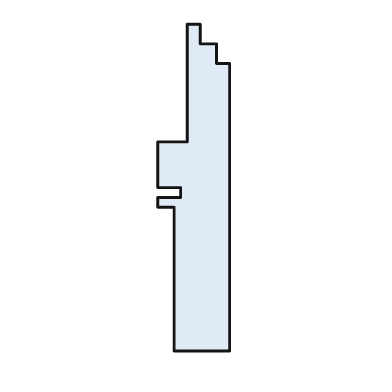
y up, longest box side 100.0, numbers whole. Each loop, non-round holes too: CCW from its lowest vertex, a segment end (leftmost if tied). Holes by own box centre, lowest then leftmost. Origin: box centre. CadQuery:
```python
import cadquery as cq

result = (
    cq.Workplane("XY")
    .moveTo(-6.0, -50.0)
    .lineTo(11.0, -50.0)
    .lineTo(11.0, 38.0)
    .lineTo(7.0, 38.0)
    .lineTo(7.0, 44.0)
    .lineTo(2.0, 44.0)
    .lineTo(2.0, 50.0)
    .lineTo(-2.0, 50.0)
    .lineTo(-2.0, 14.0)
    .lineTo(-11.0, 14.0)
    .lineTo(-11.0, 0.0)
    .lineTo(-4.0, 0.0)
    .lineTo(-4.0, -3.0)
    .lineTo(-11.0, -3.0)
    .lineTo(-11.0, -6.0)
    .lineTo(-6.0, -6.0)
    .close()
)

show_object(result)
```